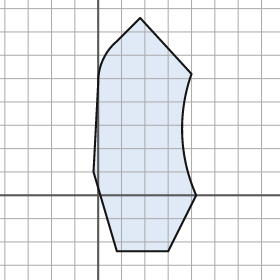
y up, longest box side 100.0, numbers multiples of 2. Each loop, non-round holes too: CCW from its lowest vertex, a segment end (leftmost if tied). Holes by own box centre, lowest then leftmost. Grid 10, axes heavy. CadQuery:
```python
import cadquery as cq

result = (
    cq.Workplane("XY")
    .moveTo(8.0, -24.0)
    .lineTo(30.0, -24.0)
    .lineTo(42.0, 0.0)
    .threePointArc((36.0, 26.0), (40.0, 52.0))
    .lineTo(18.0, 76.0)
    .lineTo(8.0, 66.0)
    .threePointArc((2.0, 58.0), (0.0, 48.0))
    .lineTo(-2.0, 10.0)
    .close()
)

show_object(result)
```